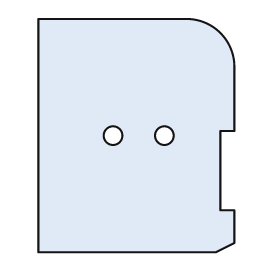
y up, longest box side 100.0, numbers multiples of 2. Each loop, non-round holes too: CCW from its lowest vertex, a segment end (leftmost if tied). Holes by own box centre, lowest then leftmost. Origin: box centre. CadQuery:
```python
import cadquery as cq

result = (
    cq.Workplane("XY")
    .moveTo(-42.0, -50.0)
    .lineTo(34.0, -50.0)
    .lineTo(42.0, -46.0)
    .lineTo(42.0, -32.0)
    .lineTo(36.0, -32.0)
    .lineTo(36.0, 2.0)
    .lineTo(42.0, 2.0)
    .lineTo(42.0, 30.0)
    .threePointArc((36.0, 44.0), (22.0, 50.0))
    .lineTo(-42.0, 50.0)
    .close()
    .moveTo(-10.0, 0.0)
    .circle(4.0)
    .moveTo(12.0, 0.0)
    .circle(4.0)
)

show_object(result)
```